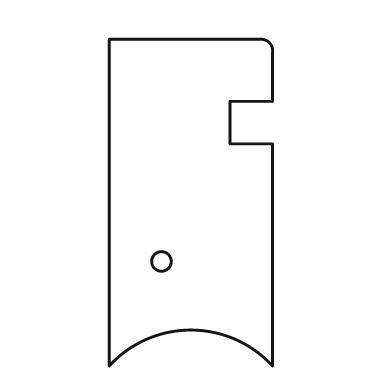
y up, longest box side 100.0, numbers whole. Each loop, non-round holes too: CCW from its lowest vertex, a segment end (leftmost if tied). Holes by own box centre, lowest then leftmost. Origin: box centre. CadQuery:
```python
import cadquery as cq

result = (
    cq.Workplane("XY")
    .moveTo(-25.0, -50.0)
    .threePointArc((0.0, -39.0), (25.0, -50.0))
    .lineTo(25.0, 18.0)
    .lineTo(12.0, 18.0)
    .lineTo(12.0, 31.0)
    .lineTo(25.0, 31.0)
    .lineTo(25.0, 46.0)
    .threePointArc((24.0, 49.0), (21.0, 50.0))
    .lineTo(-25.0, 50.0)
    .close()
    .moveTo(-9.0, -18.0)
    .circle(3.0)
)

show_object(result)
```